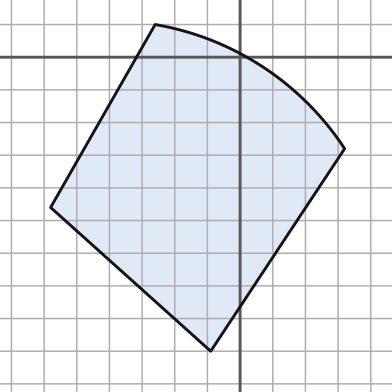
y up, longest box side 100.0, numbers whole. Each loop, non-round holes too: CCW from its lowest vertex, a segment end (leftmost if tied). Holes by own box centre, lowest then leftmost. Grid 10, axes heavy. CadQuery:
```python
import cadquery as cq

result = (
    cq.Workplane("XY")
    .moveTo(-9.0, -90.0)
    .lineTo(32.0, -28.0)
    .threePointArc((7.0, -3.0), (-26.0, 10.0))
    .lineTo(-58.0, -46.0)
    .close()
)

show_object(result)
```